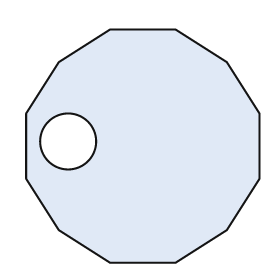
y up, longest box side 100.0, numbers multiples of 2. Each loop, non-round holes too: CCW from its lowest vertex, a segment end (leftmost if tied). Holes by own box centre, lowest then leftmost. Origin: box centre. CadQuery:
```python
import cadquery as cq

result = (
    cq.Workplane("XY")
    .moveTo(-14.0, -50.0)
    .lineTo(14.0, -50.0)
    .lineTo(36.0, -36.0)
    .lineTo(50.0, -14.0)
    .lineTo(50.0, 14.0)
    .lineTo(36.0, 36.0)
    .lineTo(14.0, 50.0)
    .lineTo(-14.0, 50.0)
    .lineTo(-36.0, 36.0)
    .lineTo(-50.0, 14.0)
    .lineTo(-50.0, -14.0)
    .lineTo(-36.0, -36.0)
    .close()
    .moveTo(-32.0, 2.0)
    .circle(12.0)
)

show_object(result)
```